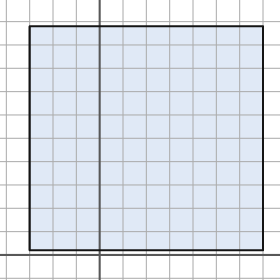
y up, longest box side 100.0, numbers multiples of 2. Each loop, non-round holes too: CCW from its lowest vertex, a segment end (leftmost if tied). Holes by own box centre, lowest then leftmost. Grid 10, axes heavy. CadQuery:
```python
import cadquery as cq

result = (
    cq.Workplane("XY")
    .moveTo(-30.0, 2.0)
    .lineTo(70.0, 2.0)
    .lineTo(70.0, 98.0)
    .lineTo(-30.0, 98.0)
    .close()
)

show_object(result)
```